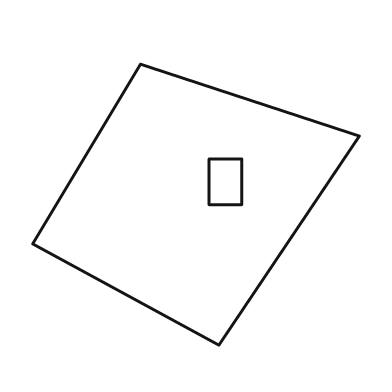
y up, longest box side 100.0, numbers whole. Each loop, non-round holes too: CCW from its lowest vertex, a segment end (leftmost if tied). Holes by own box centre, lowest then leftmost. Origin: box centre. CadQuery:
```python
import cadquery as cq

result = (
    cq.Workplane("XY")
    .moveTo(7.0, -43.0)
    .lineTo(50.0, 21.0)
    .lineTo(-17.0, 43.0)
    .lineTo(-50.0, -12.0)
    .close()
    .moveTo(4.0, 0.0)
    .lineTo(14.0, 0.0)
    .lineTo(14.0, 14.0)
    .lineTo(4.0, 14.0)
    .close()
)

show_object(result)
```